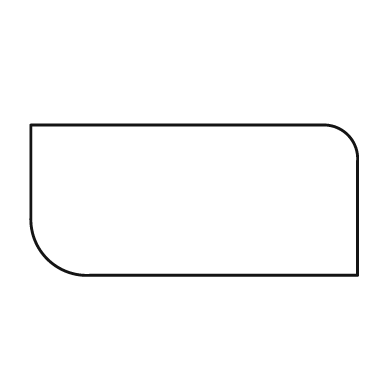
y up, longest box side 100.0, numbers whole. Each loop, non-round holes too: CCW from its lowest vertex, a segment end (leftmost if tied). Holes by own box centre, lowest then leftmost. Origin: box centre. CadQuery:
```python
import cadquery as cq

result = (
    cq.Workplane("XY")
    .moveTo(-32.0, -23.0)
    .lineTo(50.0, -23.0)
    .lineTo(50.0, 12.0)
    .threePointArc((47.0, 20.0), (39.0, 23.0))
    .lineTo(-50.0, 23.0)
    .lineTo(-50.0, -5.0)
    .threePointArc((-45.0, -18.0), (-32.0, -23.0))
    .close()
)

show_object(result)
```